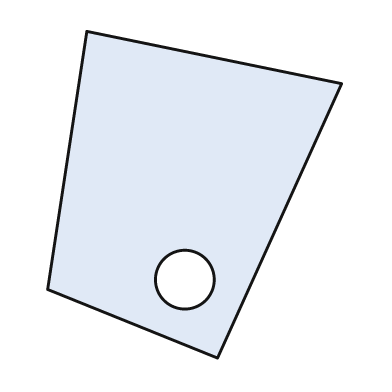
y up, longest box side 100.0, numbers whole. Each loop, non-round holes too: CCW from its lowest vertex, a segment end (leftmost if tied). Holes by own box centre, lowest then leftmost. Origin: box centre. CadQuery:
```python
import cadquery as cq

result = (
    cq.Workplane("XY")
    .moveTo(7.0, -50.0)
    .lineTo(45.0, 34.0)
    .lineTo(-33.0, 50.0)
    .lineTo(-45.0, -29.0)
    .close()
    .moveTo(-3.0, -26.0)
    .circle(9.0)
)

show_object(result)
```